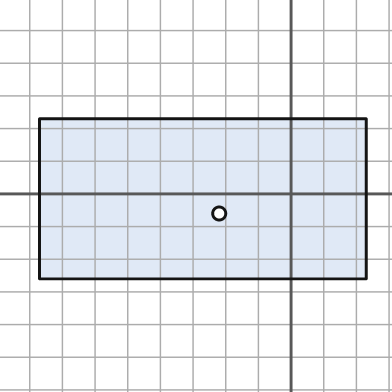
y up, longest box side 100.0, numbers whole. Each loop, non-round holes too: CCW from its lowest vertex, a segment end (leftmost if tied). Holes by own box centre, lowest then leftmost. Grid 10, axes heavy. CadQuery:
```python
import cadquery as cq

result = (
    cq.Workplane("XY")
    .moveTo(-77.0, -26.0)
    .lineTo(23.0, -26.0)
    .lineTo(23.0, 23.0)
    .lineTo(-77.0, 23.0)
    .close()
    .moveTo(-22.0, -6.0)
    .circle(2.0)
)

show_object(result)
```